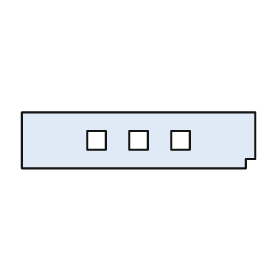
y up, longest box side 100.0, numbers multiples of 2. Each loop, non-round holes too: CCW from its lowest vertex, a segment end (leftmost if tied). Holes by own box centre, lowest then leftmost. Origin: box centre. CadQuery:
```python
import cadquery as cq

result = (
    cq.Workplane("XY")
    .moveTo(-50.0, -12.0)
    .lineTo(46.0, -12.0)
    .lineTo(46.0, -8.0)
    .lineTo(50.0, -8.0)
    .lineTo(50.0, 12.0)
    .lineTo(-50.0, 12.0)
    .close()
    .moveTo(-22.0, -4.0)
    .lineTo(-14.0, -4.0)
    .lineTo(-14.0, 4.0)
    .lineTo(-22.0, 4.0)
    .close()
    .moveTo(-4.0, -4.0)
    .lineTo(4.0, -4.0)
    .lineTo(4.0, 4.0)
    .lineTo(-4.0, 4.0)
    .close()
    .moveTo(14.0, -4.0)
    .lineTo(22.0, -4.0)
    .lineTo(22.0, 4.0)
    .lineTo(14.0, 4.0)
    .close()
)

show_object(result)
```